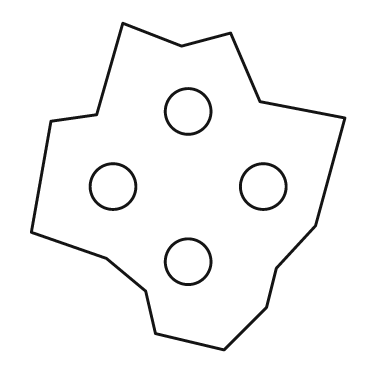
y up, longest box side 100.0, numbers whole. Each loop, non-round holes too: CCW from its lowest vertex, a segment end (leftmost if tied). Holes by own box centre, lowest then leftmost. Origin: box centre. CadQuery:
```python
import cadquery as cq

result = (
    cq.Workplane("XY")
    .moveTo(11.0, -50.0)
    .lineTo(24.0, -37.0)
    .lineTo(27.0, -25.0)
    .lineTo(39.0, -12.0)
    .lineTo(48.0, 21.0)
    .lineTo(22.0, 26.0)
    .lineTo(13.0, 47.0)
    .lineTo(-2.0, 43.0)
    .lineTo(-20.0, 50.0)
    .lineTo(-28.0, 22.0)
    .lineTo(-42.0, 20.0)
    .lineTo(-48.0, -14.0)
    .lineTo(-25.0, -22.0)
    .lineTo(-13.0, -32.0)
    .lineTo(-10.0, -45.0)
    .close()
    .moveTo(0.0, -23.0)
    .circle(7.0)
    .moveTo(-23.0, 0.0)
    .circle(7.0)
    .moveTo(23.0, 0.0)
    .circle(7.0)
    .moveTo(0.0, 23.0)
    .circle(7.0)
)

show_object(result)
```